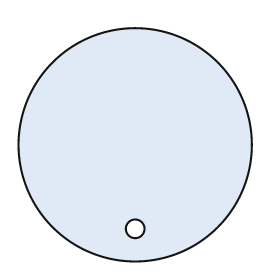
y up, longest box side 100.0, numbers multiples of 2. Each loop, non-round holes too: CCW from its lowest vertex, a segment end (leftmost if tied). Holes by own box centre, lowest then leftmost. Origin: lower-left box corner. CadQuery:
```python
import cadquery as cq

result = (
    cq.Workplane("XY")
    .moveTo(50.0, 50.0)
    .circle(50.0)
    .moveTo(50.0, 14.0)
    .circle(4.0)
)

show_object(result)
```